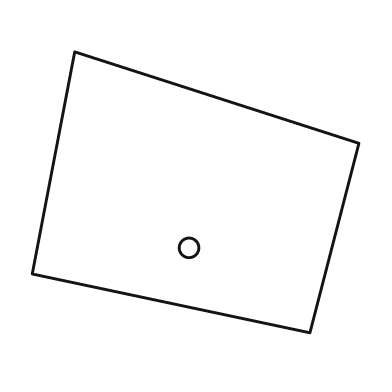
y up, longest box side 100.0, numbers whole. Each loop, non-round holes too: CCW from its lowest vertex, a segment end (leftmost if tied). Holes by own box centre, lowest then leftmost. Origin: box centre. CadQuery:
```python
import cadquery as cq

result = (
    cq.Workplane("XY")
    .moveTo(35.0, -43.0)
    .lineTo(50.0, 15.0)
    .lineTo(-37.0, 43.0)
    .lineTo(-50.0, -25.0)
    .close()
    .moveTo(-2.0, -17.0)
    .circle(3.0)
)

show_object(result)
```